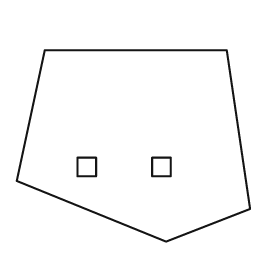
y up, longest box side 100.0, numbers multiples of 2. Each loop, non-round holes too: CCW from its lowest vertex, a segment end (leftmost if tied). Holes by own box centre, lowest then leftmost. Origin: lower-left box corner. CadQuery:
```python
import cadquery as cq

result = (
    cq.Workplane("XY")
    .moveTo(64.0, 0.0)
    .lineTo(100.0, 14.0)
    .lineTo(90.0, 82.0)
    .lineTo(12.0, 82.0)
    .lineTo(0.0, 26.0)
    .close()
    .moveTo(26.0, 28.0)
    .lineTo(34.0, 28.0)
    .lineTo(34.0, 36.0)
    .lineTo(26.0, 36.0)
    .close()
    .moveTo(58.0, 28.0)
    .lineTo(66.0, 28.0)
    .lineTo(66.0, 36.0)
    .lineTo(58.0, 36.0)
    .close()
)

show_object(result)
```